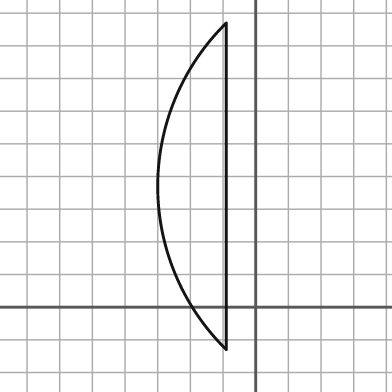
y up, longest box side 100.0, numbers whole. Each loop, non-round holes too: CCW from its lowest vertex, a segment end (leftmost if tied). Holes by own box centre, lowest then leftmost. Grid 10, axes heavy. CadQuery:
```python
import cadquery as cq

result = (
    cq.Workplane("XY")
    .moveTo(-9.0, -13.0)
    .lineTo(-9.0, 87.0)
    .threePointArc((-30.0, 37.0), (-9.0, -13.0))
    .close()
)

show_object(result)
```